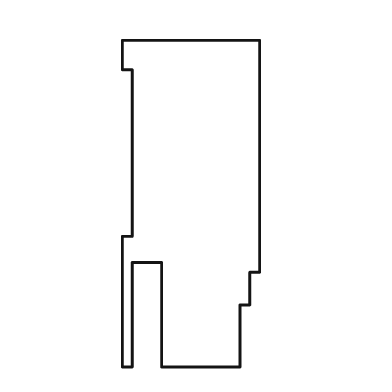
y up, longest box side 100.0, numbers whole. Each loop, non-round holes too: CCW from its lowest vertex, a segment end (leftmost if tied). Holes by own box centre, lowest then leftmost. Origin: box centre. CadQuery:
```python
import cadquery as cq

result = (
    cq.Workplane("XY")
    .moveTo(-21.0, -50.0)
    .lineTo(-18.0, -50.0)
    .lineTo(-18.0, -18.0)
    .lineTo(-9.0, -18.0)
    .lineTo(-9.0, -50.0)
    .lineTo(15.0, -50.0)
    .lineTo(15.0, -31.0)
    .lineTo(18.0, -31.0)
    .lineTo(18.0, -21.0)
    .lineTo(21.0, -21.0)
    .lineTo(21.0, 50.0)
    .lineTo(-21.0, 50.0)
    .lineTo(-21.0, 41.0)
    .lineTo(-18.0, 41.0)
    .lineTo(-18.0, -10.0)
    .lineTo(-21.0, -10.0)
    .close()
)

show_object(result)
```